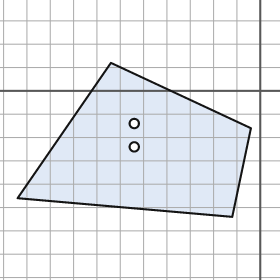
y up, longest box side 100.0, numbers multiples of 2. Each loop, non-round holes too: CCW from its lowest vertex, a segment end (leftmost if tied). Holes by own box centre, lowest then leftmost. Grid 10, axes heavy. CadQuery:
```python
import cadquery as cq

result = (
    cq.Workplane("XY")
    .moveTo(-12.0, -54.0)
    .lineTo(-4.0, -16.0)
    .lineTo(-64.0, 12.0)
    .lineTo(-104.0, -46.0)
    .close()
    .moveTo(-54.0, -24.0)
    .circle(2.0)
    .moveTo(-54.0, -14.0)
    .circle(2.0)
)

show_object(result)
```